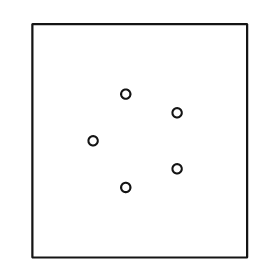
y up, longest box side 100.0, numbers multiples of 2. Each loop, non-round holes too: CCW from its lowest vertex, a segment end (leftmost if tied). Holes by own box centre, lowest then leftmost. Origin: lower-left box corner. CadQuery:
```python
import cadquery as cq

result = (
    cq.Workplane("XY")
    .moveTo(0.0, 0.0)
    .lineTo(92.0, 0.0)
    .lineTo(92.0, 100.0)
    .lineTo(0.0, 100.0)
    .close()
    .moveTo(40.0, 30.0)
    .circle(2.0)
    .moveTo(62.0, 38.0)
    .circle(2.0)
    .moveTo(26.0, 50.0)
    .circle(2.0)
    .moveTo(62.0, 62.0)
    .circle(2.0)
    .moveTo(40.0, 70.0)
    .circle(2.0)
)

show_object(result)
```